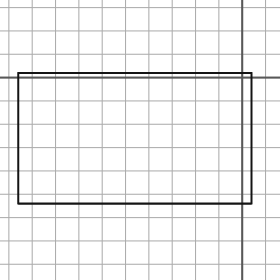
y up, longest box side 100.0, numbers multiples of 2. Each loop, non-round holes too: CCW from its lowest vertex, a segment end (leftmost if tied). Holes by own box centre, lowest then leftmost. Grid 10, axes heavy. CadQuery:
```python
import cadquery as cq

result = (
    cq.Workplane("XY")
    .moveTo(-96.0, -54.0)
    .lineTo(4.0, -54.0)
    .lineTo(4.0, 2.0)
    .lineTo(-96.0, 2.0)
    .close()
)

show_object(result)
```